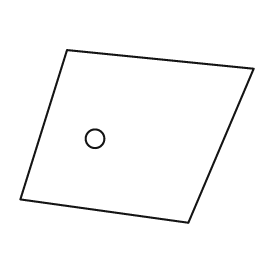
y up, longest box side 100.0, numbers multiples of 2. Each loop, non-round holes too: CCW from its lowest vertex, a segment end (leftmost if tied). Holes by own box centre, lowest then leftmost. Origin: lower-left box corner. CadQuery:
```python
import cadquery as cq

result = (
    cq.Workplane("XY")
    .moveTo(72.0, 0.0)
    .lineTo(100.0, 66.0)
    .lineTo(20.0, 74.0)
    .lineTo(0.0, 10.0)
    .close()
    .moveTo(32.0, 36.0)
    .circle(4.0)
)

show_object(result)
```